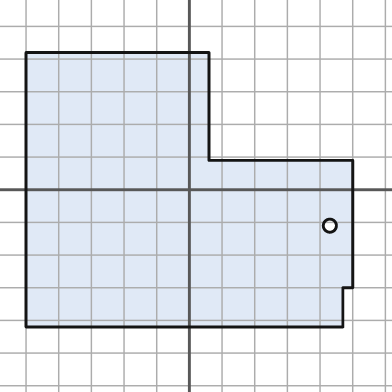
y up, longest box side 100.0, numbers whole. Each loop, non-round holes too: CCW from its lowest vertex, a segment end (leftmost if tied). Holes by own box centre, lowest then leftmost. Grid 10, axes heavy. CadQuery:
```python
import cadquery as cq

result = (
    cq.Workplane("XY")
    .moveTo(-50.0, -42.0)
    .lineTo(47.0, -42.0)
    .lineTo(47.0, -30.0)
    .lineTo(50.0, -30.0)
    .lineTo(50.0, 9.0)
    .lineTo(6.0, 9.0)
    .lineTo(6.0, 42.0)
    .lineTo(-50.0, 42.0)
    .close()
    .moveTo(43.0, -11.0)
    .circle(2.0)
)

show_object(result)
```